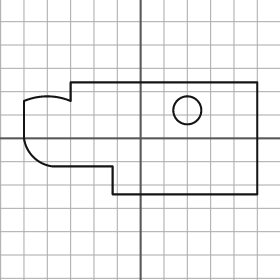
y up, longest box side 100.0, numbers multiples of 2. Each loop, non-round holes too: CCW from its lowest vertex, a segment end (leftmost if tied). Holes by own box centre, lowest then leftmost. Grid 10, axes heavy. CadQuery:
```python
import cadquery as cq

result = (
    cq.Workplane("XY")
    .moveTo(-12.0, -24.0)
    .lineTo(50.0, -24.0)
    .lineTo(50.0, 24.0)
    .lineTo(-30.0, 24.0)
    .lineTo(-30.0, 16.0)
    .threePointArc((-40.0, 18.0), (-50.0, 16.0))
    .lineTo(-50.0, 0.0)
    .threePointArc((-46.0, -8.0), (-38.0, -12.0))
    .lineTo(-12.0, -12.0)
    .close()
    .moveTo(20.0, 12.0)
    .circle(6.0)
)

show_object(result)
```